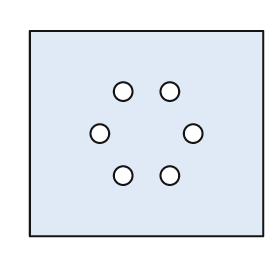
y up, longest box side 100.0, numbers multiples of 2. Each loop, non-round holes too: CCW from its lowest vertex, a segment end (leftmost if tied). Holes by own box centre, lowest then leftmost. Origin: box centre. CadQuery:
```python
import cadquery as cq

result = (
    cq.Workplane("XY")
    .moveTo(-50.0, -44.0)
    .lineTo(50.0, -44.0)
    .lineTo(50.0, 44.0)
    .lineTo(-50.0, 44.0)
    .close()
    .moveTo(-10.0, -18.0)
    .circle(4.0)
    .moveTo(10.0, -18.0)
    .circle(4.0)
    .moveTo(-20.0, 0.0)
    .circle(4.0)
    .moveTo(20.0, 0.0)
    .circle(4.0)
    .moveTo(-10.0, 18.0)
    .circle(4.0)
    .moveTo(10.0, 18.0)
    .circle(4.0)
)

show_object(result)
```